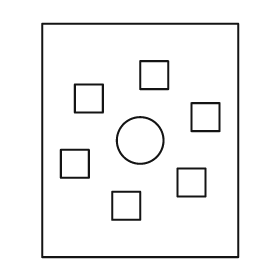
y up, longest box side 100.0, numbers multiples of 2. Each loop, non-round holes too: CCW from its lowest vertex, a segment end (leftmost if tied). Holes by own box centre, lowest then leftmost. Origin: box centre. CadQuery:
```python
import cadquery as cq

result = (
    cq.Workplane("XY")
    .moveTo(-42.0, -50.0)
    .lineTo(42.0, -50.0)
    .lineTo(42.0, 50.0)
    .lineTo(-42.0, 50.0)
    .close()
    .moveTo(-12.0, -34.0)
    .lineTo(0.0, -34.0)
    .lineTo(0.0, -22.0)
    .lineTo(-12.0, -22.0)
    .close()
    .moveTo(16.0, -24.0)
    .lineTo(28.0, -24.0)
    .lineTo(28.0, -12.0)
    .lineTo(16.0, -12.0)
    .close()
    .moveTo(-34.0, -16.0)
    .lineTo(-22.0, -16.0)
    .lineTo(-22.0, -4.0)
    .lineTo(-34.0, -4.0)
    .close()
    .moveTo(0.0, 0.0)
    .circle(10.0)
    .moveTo(22.0, 4.0)
    .lineTo(34.0, 4.0)
    .lineTo(34.0, 16.0)
    .lineTo(22.0, 16.0)
    .close()
    .moveTo(-28.0, 12.0)
    .lineTo(-16.0, 12.0)
    .lineTo(-16.0, 24.0)
    .lineTo(-28.0, 24.0)
    .close()
    .moveTo(0.0, 22.0)
    .lineTo(12.0, 22.0)
    .lineTo(12.0, 34.0)
    .lineTo(0.0, 34.0)
    .close()
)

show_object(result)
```